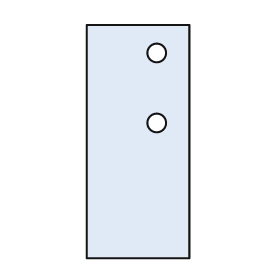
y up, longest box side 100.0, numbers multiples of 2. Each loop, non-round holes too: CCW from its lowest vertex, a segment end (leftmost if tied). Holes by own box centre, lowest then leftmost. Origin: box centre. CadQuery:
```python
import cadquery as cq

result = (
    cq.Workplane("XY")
    .moveTo(-22.0, -50.0)
    .lineTo(22.0, -50.0)
    .lineTo(22.0, 50.0)
    .lineTo(-22.0, 50.0)
    .close()
    .moveTo(8.0, 8.0)
    .circle(4.0)
    .moveTo(8.0, 38.0)
    .circle(4.0)
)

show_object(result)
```